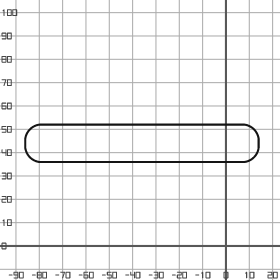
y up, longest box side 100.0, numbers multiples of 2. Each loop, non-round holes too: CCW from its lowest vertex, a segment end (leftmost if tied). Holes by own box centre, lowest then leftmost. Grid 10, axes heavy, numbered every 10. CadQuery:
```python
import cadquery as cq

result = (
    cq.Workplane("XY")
    .moveTo(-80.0, 36.0)
    .lineTo(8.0, 36.0)
    .threePointArc((12.0, 38.0), (14.0, 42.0))
    .lineTo(14.0, 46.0)
    .threePointArc((12.0, 50.0), (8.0, 52.0))
    .lineTo(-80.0, 52.0)
    .threePointArc((-84.0, 50.0), (-86.0, 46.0))
    .lineTo(-86.0, 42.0)
    .threePointArc((-84.0, 38.0), (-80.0, 36.0))
    .close()
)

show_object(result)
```